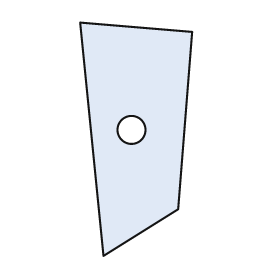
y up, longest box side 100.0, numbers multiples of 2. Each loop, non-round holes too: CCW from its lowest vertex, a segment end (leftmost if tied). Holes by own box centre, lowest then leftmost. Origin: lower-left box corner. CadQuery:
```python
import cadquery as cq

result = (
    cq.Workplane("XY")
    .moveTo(10.0, 0.0)
    .lineTo(42.0, 20.0)
    .lineTo(48.0, 96.0)
    .lineTo(0.0, 100.0)
    .close()
    .moveTo(22.0, 54.0)
    .circle(6.0)
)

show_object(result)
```